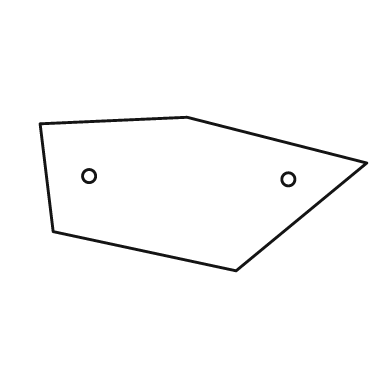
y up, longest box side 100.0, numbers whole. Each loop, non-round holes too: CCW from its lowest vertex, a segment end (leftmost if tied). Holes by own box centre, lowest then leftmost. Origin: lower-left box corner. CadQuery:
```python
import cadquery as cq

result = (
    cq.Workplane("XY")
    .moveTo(60.0, 0.0)
    .lineTo(100.0, 33.0)
    .lineTo(45.0, 47.0)
    .lineTo(0.0, 45.0)
    .lineTo(4.0, 12.0)
    .close()
    .moveTo(76.0, 28.0)
    .circle(2.0)
    .moveTo(15.0, 29.0)
    .circle(2.0)
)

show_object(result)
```